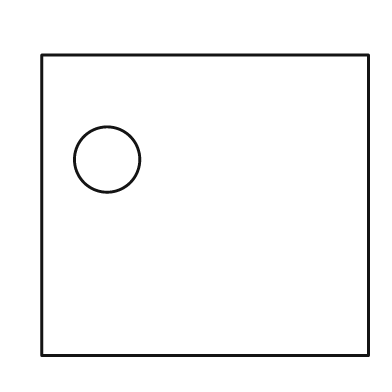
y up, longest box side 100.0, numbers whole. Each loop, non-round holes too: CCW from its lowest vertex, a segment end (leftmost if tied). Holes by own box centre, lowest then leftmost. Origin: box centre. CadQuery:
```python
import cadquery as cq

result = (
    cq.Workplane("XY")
    .moveTo(-50.0, -46.0)
    .lineTo(50.0, -46.0)
    .lineTo(50.0, 46.0)
    .lineTo(-50.0, 46.0)
    .close()
    .moveTo(-30.0, 14.0)
    .circle(10.0)
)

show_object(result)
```